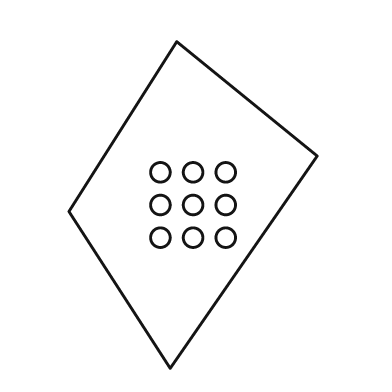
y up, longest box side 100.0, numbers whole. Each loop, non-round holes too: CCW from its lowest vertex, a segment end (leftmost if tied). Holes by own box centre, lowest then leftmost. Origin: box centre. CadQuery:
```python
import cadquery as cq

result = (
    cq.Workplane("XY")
    .moveTo(-7.0, -50.0)
    .lineTo(38.0, 15.0)
    .lineTo(-5.0, 50.0)
    .lineTo(-38.0, -2.0)
    .close()
    .moveTo(-10.0, -10.0)
    .circle(3.0)
    .moveTo(0.0, -10.0)
    .circle(3.0)
    .moveTo(10.0, -10.0)
    .circle(3.0)
    .moveTo(-10.0, 0.0)
    .circle(3.0)
    .moveTo(0.0, 0.0)
    .circle(3.0)
    .moveTo(10.0, 0.0)
    .circle(3.0)
    .moveTo(-10.0, 10.0)
    .circle(3.0)
    .moveTo(0.0, 10.0)
    .circle(3.0)
    .moveTo(10.0, 10.0)
    .circle(3.0)
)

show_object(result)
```